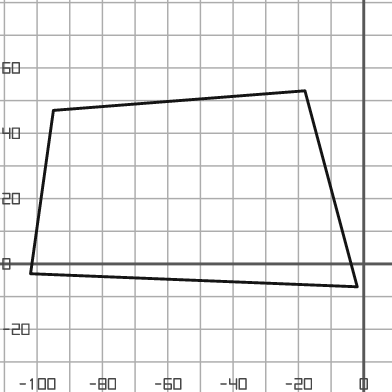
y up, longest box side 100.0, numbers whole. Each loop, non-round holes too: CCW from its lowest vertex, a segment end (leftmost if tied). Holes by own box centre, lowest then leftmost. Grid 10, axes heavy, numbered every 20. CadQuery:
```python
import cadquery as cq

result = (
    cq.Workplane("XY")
    .moveTo(-2.0, -7.0)
    .lineTo(-18.0, 53.0)
    .lineTo(-95.0, 47.0)
    .lineTo(-102.0, -3.0)
    .close()
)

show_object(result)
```